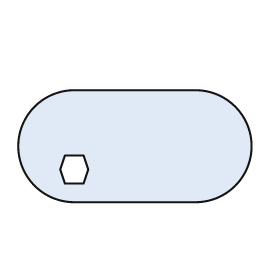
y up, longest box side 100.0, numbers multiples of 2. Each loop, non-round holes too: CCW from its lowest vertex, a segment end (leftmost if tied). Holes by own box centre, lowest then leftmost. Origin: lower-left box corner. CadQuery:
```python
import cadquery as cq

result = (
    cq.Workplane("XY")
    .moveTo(24.0, 0.0)
    .lineTo(76.0, 0.0)
    .threePointArc((100.0, 24.0), (76.0, 48.0))
    .lineTo(24.0, 48.0)
    .threePointArc((0.0, 24.0), (24.0, 0.0))
    .close()
    .moveTo(20.0, 8.0)
    .lineTo(28.0, 8.0)
    .lineTo(30.0, 14.0)
    .lineTo(28.0, 20.0)
    .lineTo(20.0, 20.0)
    .lineTo(18.0, 14.0)
    .close()
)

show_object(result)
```